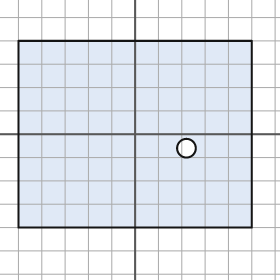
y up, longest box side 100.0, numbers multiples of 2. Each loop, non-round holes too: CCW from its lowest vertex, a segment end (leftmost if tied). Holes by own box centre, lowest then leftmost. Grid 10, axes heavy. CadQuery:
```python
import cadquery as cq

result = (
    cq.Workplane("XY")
    .moveTo(-50.0, -40.0)
    .lineTo(50.0, -40.0)
    .lineTo(50.0, 40.0)
    .lineTo(-50.0, 40.0)
    .close()
    .moveTo(22.0, -6.0)
    .circle(4.0)
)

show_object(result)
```